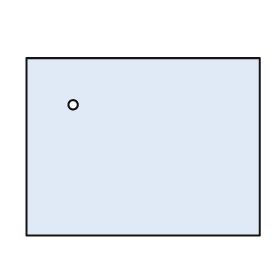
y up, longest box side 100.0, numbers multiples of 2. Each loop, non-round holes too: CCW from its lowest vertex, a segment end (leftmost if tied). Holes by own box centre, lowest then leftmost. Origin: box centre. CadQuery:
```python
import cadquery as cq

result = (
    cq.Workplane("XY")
    .moveTo(-50.0, -38.0)
    .lineTo(50.0, -38.0)
    .lineTo(50.0, 38.0)
    .lineTo(-50.0, 38.0)
    .close()
    .moveTo(-30.0, 18.0)
    .circle(2.0)
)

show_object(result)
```